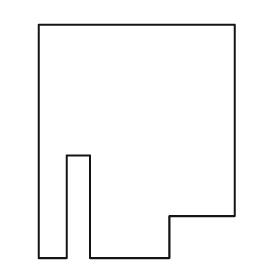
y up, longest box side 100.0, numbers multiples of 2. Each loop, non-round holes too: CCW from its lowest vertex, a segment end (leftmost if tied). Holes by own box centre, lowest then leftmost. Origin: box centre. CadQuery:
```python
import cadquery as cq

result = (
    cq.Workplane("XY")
    .moveTo(-42.0, -50.0)
    .lineTo(-30.0, -50.0)
    .lineTo(-30.0, -6.0)
    .lineTo(-20.0, -6.0)
    .lineTo(-20.0, -50.0)
    .lineTo(14.0, -50.0)
    .lineTo(14.0, -32.0)
    .lineTo(42.0, -32.0)
    .lineTo(42.0, 50.0)
    .lineTo(-42.0, 50.0)
    .close()
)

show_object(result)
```